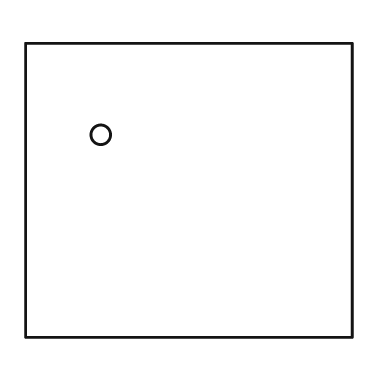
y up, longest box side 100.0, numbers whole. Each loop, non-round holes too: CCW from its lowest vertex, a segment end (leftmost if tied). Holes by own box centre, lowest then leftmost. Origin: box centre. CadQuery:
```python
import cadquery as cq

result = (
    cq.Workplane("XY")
    .moveTo(-50.0, -45.0)
    .lineTo(50.0, -45.0)
    .lineTo(50.0, 45.0)
    .lineTo(-50.0, 45.0)
    .close()
    .moveTo(-27.0, 17.0)
    .circle(3.0)
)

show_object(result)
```